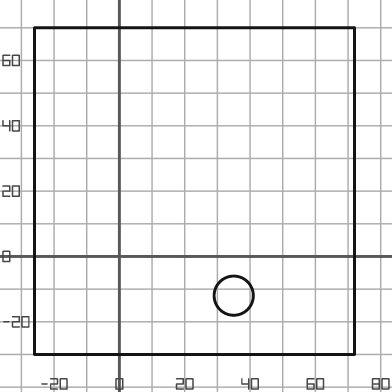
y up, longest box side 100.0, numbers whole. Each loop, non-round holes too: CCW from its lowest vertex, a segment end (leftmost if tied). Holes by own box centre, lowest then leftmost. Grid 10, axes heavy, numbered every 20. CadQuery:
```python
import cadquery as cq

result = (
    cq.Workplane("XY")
    .moveTo(-26.0, -30.0)
    .lineTo(72.0, -30.0)
    .lineTo(72.0, 70.0)
    .lineTo(-26.0, 70.0)
    .close()
    .moveTo(35.0, -12.0)
    .circle(6.0)
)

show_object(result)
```